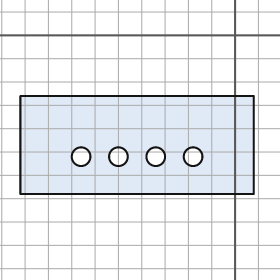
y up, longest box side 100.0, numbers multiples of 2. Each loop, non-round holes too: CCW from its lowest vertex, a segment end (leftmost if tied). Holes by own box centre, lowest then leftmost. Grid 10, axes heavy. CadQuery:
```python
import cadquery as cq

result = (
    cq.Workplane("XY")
    .moveTo(-92.0, -68.0)
    .lineTo(8.0, -68.0)
    .lineTo(8.0, -26.0)
    .lineTo(-92.0, -26.0)
    .close()
    .moveTo(-66.0, -52.0)
    .circle(4.0)
    .moveTo(-50.0, -52.0)
    .circle(4.0)
    .moveTo(-34.0, -52.0)
    .circle(4.0)
    .moveTo(-18.0, -52.0)
    .circle(4.0)
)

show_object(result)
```